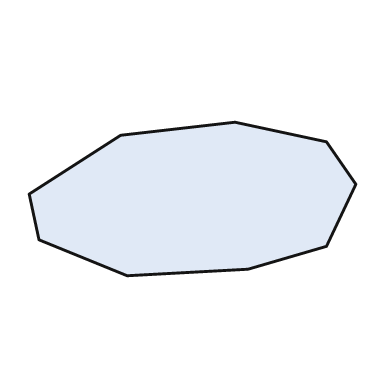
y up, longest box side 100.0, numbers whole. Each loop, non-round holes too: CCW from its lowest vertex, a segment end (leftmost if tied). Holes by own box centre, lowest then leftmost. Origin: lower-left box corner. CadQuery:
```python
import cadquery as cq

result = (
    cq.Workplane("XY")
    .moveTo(30.0, 0.0)
    .lineTo(67.0, 2.0)
    .lineTo(91.0, 9.0)
    .lineTo(100.0, 28.0)
    .lineTo(91.0, 41.0)
    .lineTo(63.0, 47.0)
    .lineTo(28.0, 43.0)
    .lineTo(0.0, 25.0)
    .lineTo(3.0, 11.0)
    .close()
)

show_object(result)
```